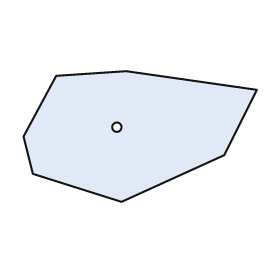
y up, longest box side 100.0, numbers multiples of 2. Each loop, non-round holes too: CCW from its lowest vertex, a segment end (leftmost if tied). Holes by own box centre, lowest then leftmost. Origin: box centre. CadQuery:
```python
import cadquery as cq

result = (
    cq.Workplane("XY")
    .moveTo(-8.0, -28.0)
    .lineTo(36.0, -8.0)
    .lineTo(50.0, 20.0)
    .lineTo(-6.0, 28.0)
    .lineTo(-36.0, 26.0)
    .lineTo(-50.0, 0.0)
    .lineTo(-46.0, -16.0)
    .close()
    .moveTo(-10.0, 4.0)
    .circle(2.0)
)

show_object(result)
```